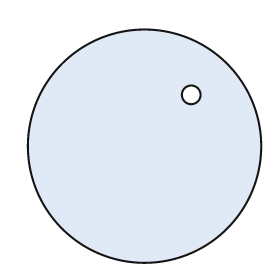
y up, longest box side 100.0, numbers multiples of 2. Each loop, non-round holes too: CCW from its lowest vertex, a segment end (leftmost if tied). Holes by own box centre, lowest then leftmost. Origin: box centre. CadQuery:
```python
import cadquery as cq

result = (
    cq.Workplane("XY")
    .moveTo(0.0, 0.0)
    .circle(50.0)
    .moveTo(20.0, 22.0)
    .circle(4.0)
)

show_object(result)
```